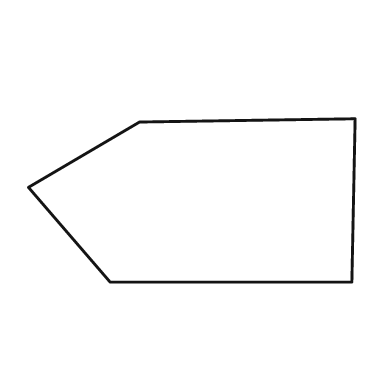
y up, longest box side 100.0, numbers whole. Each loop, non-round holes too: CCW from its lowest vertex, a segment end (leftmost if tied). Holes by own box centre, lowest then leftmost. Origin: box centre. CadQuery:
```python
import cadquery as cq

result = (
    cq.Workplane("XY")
    .moveTo(-25.0, -25.0)
    .lineTo(49.0, -25.0)
    .lineTo(50.0, 25.0)
    .lineTo(-16.0, 24.0)
    .lineTo(-50.0, 4.0)
    .close()
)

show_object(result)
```